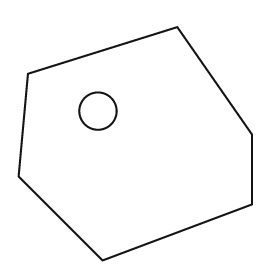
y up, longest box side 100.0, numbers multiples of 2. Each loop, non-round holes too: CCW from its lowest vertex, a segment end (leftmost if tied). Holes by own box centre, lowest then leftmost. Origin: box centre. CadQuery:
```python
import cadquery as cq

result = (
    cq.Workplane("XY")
    .moveTo(-14.0, -50.0)
    .lineTo(50.0, -26.0)
    .lineTo(50.0, 4.0)
    .lineTo(18.0, 50.0)
    .lineTo(-46.0, 30.0)
    .lineTo(-50.0, -14.0)
    .close()
    .moveTo(-16.0, 14.0)
    .circle(8.0)
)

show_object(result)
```